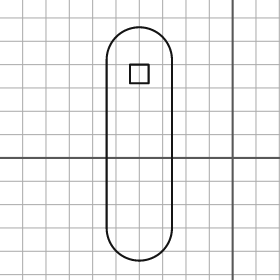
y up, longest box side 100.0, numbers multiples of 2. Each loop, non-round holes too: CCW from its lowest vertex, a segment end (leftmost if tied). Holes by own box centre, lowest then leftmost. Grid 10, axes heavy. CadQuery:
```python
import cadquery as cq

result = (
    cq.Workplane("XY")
    .moveTo(-54.0, -30.0)
    .threePointArc((-40.0, -44.0), (-26.0, -30.0))
    .lineTo(-26.0, 42.0)
    .threePointArc((-40.0, 56.0), (-54.0, 42.0))
    .close()
    .moveTo(-44.0, 32.0)
    .lineTo(-36.0, 32.0)
    .lineTo(-36.0, 40.0)
    .lineTo(-44.0, 40.0)
    .close()
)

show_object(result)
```